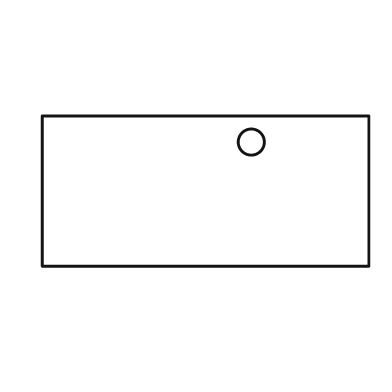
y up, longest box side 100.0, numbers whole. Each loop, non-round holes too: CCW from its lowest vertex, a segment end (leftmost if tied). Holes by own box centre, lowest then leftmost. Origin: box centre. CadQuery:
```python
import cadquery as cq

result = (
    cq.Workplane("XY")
    .moveTo(-50.0, -23.0)
    .lineTo(50.0, -23.0)
    .lineTo(50.0, 23.0)
    .lineTo(-50.0, 23.0)
    .close()
    .moveTo(14.0, 15.0)
    .circle(4.0)
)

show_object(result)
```